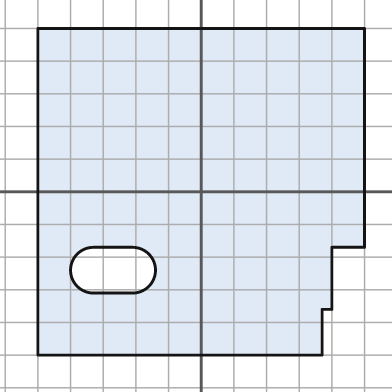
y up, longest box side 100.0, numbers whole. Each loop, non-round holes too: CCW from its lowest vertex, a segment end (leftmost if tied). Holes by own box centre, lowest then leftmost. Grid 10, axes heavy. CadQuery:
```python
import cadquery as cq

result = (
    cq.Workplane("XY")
    .moveTo(-50.0, -50.0)
    .lineTo(37.0, -50.0)
    .lineTo(37.0, -36.0)
    .lineTo(40.0, -36.0)
    .lineTo(40.0, -17.0)
    .lineTo(50.0, -17.0)
    .lineTo(50.0, 50.0)
    .lineTo(-50.0, 50.0)
    .close()
    .moveTo(-33.0, -31.0)
    .lineTo(-21.0, -31.0)
    .threePointArc((-14.0, -24.0), (-21.0, -17.0))
    .lineTo(-33.0, -17.0)
    .threePointArc((-40.0, -24.0), (-33.0, -31.0))
    .close()
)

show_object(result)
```